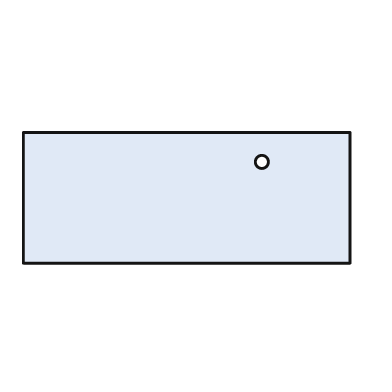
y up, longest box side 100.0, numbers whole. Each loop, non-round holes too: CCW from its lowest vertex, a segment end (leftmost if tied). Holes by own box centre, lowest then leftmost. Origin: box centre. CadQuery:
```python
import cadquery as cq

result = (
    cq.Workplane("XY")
    .moveTo(-50.0, -20.0)
    .lineTo(50.0, -20.0)
    .lineTo(50.0, 20.0)
    .lineTo(-50.0, 20.0)
    .close()
    .moveTo(23.0, 11.0)
    .circle(2.0)
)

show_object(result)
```